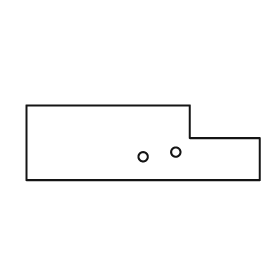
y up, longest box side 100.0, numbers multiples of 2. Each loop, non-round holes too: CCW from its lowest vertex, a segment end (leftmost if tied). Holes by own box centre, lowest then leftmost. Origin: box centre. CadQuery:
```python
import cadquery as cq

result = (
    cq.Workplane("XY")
    .moveTo(-50.0, -16.0)
    .lineTo(50.0, -16.0)
    .lineTo(50.0, 2.0)
    .lineTo(20.0, 2.0)
    .lineTo(20.0, 16.0)
    .lineTo(-50.0, 16.0)
    .close()
    .moveTo(0.0, -6.0)
    .circle(2.0)
    .moveTo(14.0, -4.0)
    .circle(2.0)
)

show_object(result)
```